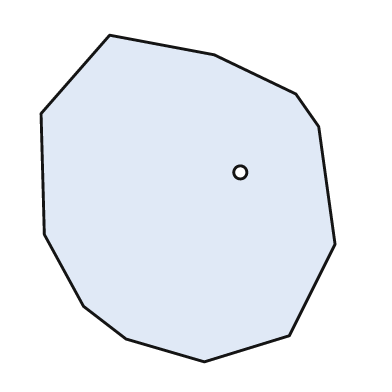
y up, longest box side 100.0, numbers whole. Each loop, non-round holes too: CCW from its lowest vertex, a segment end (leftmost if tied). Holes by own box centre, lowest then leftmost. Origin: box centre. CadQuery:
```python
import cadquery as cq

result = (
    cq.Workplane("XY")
    .moveTo(5.0, -50.0)
    .lineTo(31.0, -42.0)
    .lineTo(45.0, -14.0)
    .lineTo(40.0, 22.0)
    .lineTo(33.0, 32.0)
    .lineTo(8.0, 44.0)
    .lineTo(-24.0, 50.0)
    .lineTo(-45.0, 26.0)
    .lineTo(-44.0, -11.0)
    .lineTo(-32.0, -33.0)
    .lineTo(-19.0, -43.0)
    .close()
    .moveTo(16.0, 8.0)
    .circle(2.0)
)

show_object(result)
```